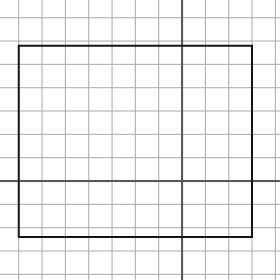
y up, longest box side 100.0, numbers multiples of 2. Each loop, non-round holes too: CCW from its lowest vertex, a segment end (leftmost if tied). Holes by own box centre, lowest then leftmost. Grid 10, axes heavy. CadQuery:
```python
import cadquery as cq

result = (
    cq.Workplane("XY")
    .moveTo(-70.0, -24.0)
    .lineTo(30.0, -24.0)
    .lineTo(30.0, 58.0)
    .lineTo(-70.0, 58.0)
    .close()
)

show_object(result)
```